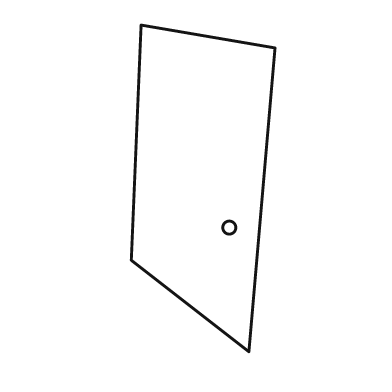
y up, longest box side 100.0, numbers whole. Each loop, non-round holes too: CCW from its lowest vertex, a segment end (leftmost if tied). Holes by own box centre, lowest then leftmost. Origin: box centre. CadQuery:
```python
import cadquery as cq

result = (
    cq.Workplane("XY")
    .moveTo(14.0, -50.0)
    .lineTo(22.0, 43.0)
    .lineTo(-19.0, 50.0)
    .lineTo(-22.0, -22.0)
    .close()
    .moveTo(8.0, -12.0)
    .circle(2.0)
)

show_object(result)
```